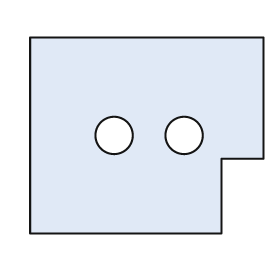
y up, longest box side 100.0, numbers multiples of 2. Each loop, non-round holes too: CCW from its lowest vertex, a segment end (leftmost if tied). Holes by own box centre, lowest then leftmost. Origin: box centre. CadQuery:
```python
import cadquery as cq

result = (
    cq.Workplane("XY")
    .moveTo(-50.0, -42.0)
    .lineTo(32.0, -42.0)
    .lineTo(32.0, -10.0)
    .lineTo(50.0, -10.0)
    .lineTo(50.0, 42.0)
    .lineTo(-50.0, 42.0)
    .close()
    .moveTo(-14.0, 0.0)
    .circle(8.0)
    .moveTo(16.0, 0.0)
    .circle(8.0)
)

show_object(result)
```